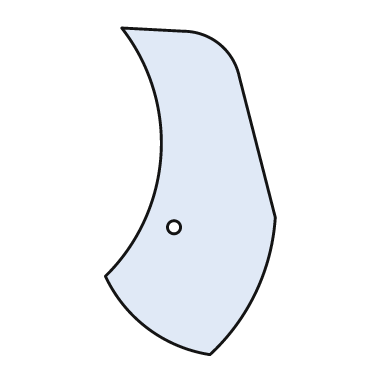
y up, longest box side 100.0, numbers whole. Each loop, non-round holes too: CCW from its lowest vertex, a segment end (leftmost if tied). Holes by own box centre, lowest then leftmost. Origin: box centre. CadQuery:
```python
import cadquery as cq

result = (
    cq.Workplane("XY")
    .moveTo(6.0, -50.0)
    .threePointArc((20.0, -31.0), (26.0, -8.0))
    .lineTo(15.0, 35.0)
    .threePointArc((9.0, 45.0), (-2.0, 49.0))
    .lineTo(-21.0, 50.0)
    .threePointArc((-9.0, 11.0), (-26.0, -26.0))
    .threePointArc((-13.0, -42.0), (6.0, -50.0))
    .close()
    .moveTo(-5.0, -11.0)
    .circle(2.0)
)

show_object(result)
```